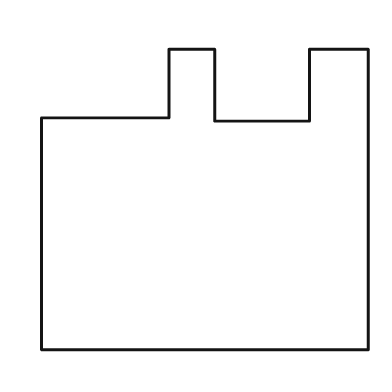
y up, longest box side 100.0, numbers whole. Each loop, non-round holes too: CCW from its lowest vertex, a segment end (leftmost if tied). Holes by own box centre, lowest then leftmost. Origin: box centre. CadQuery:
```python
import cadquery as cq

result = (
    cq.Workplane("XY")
    .moveTo(-50.0, -46.0)
    .lineTo(50.0, -46.0)
    .lineTo(50.0, 46.0)
    .lineTo(32.0, 46.0)
    .lineTo(32.0, 24.0)
    .lineTo(3.0, 24.0)
    .lineTo(3.0, 46.0)
    .lineTo(-11.0, 46.0)
    .lineTo(-11.0, 25.0)
    .lineTo(-50.0, 25.0)
    .close()
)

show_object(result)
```